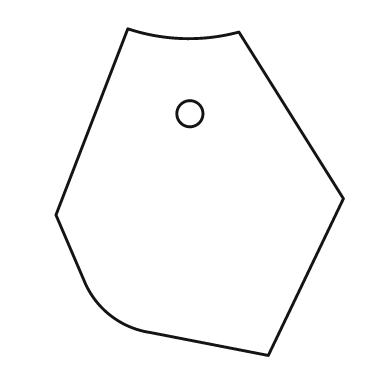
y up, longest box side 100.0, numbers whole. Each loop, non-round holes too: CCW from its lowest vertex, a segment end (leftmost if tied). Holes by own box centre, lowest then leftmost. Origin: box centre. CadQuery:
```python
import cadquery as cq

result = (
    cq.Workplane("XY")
    .moveTo(21.0, -50.0)
    .lineTo(44.0, -2.0)
    .lineTo(12.0, 49.0)
    .threePointArc((-5.0, 47.0), (-22.0, 50.0))
    .lineTo(-44.0, -7.0)
    .lineTo(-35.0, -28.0)
    .threePointArc((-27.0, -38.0), (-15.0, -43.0))
    .close()
    .moveTo(-3.0, 24.0)
    .circle(4.0)
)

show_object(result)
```